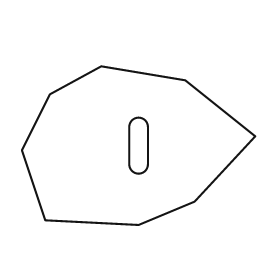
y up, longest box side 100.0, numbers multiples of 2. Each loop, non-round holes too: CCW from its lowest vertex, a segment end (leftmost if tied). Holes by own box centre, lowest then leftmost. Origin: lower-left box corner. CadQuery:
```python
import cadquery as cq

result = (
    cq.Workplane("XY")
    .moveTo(50.0, 0.0)
    .lineTo(74.0, 10.0)
    .lineTo(100.0, 38.0)
    .lineTo(70.0, 62.0)
    .lineTo(34.0, 68.0)
    .lineTo(12.0, 56.0)
    .lineTo(0.0, 32.0)
    .lineTo(10.0, 2.0)
    .close()
    .moveTo(46.0, 26.0)
    .threePointArc((50.0, 22.0), (54.0, 26.0))
    .lineTo(54.0, 42.0)
    .threePointArc((50.0, 46.0), (46.0, 42.0))
    .close()
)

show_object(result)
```